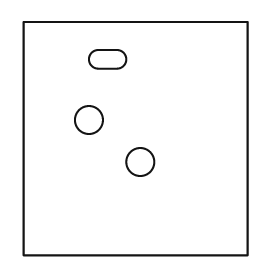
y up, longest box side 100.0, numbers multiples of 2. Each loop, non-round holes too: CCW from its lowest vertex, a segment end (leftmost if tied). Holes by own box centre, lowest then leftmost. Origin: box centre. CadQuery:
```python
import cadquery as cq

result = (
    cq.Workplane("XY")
    .moveTo(-48.0, -50.0)
    .lineTo(48.0, -50.0)
    .lineTo(48.0, 50.0)
    .lineTo(-48.0, 50.0)
    .close()
    .moveTo(2.0, -10.0)
    .circle(6.0)
    .moveTo(-20.0, 8.0)
    .circle(6.0)
    .moveTo(-16.0, 30.0)
    .lineTo(-8.0, 30.0)
    .threePointArc((-4.0, 34.0), (-8.0, 38.0))
    .lineTo(-16.0, 38.0)
    .threePointArc((-20.0, 34.0), (-16.0, 30.0))
    .close()
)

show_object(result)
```